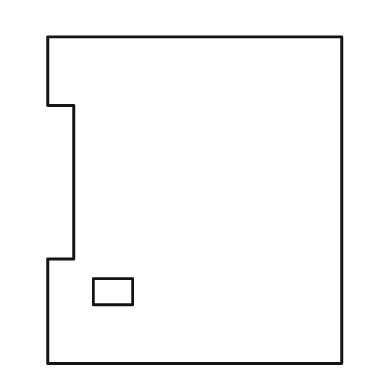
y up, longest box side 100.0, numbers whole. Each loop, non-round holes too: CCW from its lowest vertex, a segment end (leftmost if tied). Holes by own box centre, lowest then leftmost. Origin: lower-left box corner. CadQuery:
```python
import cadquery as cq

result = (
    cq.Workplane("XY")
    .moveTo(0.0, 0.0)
    .lineTo(90.0, 0.0)
    .lineTo(90.0, 100.0)
    .lineTo(0.0, 100.0)
    .lineTo(0.0, 79.0)
    .lineTo(8.0, 79.0)
    .lineTo(8.0, 32.0)
    .lineTo(0.0, 32.0)
    .close()
    .moveTo(14.0, 18.0)
    .lineTo(26.0, 18.0)
    .lineTo(26.0, 26.0)
    .lineTo(14.0, 26.0)
    .close()
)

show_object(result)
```